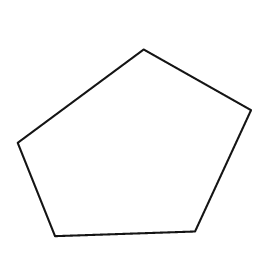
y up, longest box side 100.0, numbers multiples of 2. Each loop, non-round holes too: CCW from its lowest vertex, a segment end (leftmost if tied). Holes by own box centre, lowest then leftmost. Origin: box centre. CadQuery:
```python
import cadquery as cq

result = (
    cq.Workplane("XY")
    .moveTo(-34.0, -40.0)
    .lineTo(26.0, -38.0)
    .lineTo(50.0, 14.0)
    .lineTo(4.0, 40.0)
    .lineTo(-50.0, 0.0)
    .close()
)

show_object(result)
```